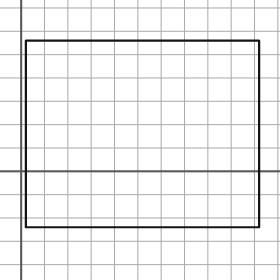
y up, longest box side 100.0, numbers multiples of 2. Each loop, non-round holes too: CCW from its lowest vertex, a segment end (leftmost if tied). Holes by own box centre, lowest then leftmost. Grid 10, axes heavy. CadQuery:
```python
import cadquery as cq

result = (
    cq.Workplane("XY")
    .moveTo(2.0, -24.0)
    .lineTo(102.0, -24.0)
    .lineTo(102.0, 56.0)
    .lineTo(2.0, 56.0)
    .close()
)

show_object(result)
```